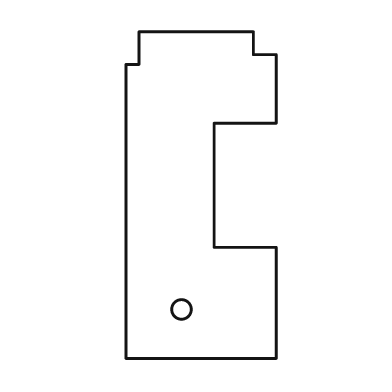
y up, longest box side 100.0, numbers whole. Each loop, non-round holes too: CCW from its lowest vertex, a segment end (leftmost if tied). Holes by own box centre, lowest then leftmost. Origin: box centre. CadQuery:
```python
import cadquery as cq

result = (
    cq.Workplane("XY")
    .moveTo(-23.0, -50.0)
    .lineTo(23.0, -50.0)
    .lineTo(23.0, -16.0)
    .lineTo(4.0, -16.0)
    .lineTo(4.0, 22.0)
    .lineTo(23.0, 22.0)
    .lineTo(23.0, 43.0)
    .lineTo(16.0, 43.0)
    .lineTo(16.0, 50.0)
    .lineTo(-19.0, 50.0)
    .lineTo(-19.0, 40.0)
    .lineTo(-23.0, 40.0)
    .close()
    .moveTo(-6.0, -35.0)
    .circle(3.0)
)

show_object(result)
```